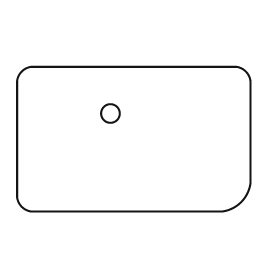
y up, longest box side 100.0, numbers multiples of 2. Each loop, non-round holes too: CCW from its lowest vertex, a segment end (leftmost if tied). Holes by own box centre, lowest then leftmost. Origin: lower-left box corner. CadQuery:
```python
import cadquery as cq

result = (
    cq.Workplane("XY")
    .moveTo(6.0, 0.0)
    .lineTo(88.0, 0.0)
    .threePointArc((96.0, 4.0), (100.0, 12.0))
    .lineTo(100.0, 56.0)
    .threePointArc((98.0, 60.0), (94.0, 62.0))
    .lineTo(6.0, 62.0)
    .threePointArc((2.0, 60.0), (0.0, 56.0))
    .lineTo(0.0, 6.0)
    .threePointArc((2.0, 2.0), (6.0, 0.0))
    .close()
    .moveTo(40.0, 42.0)
    .circle(4.0)
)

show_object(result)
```